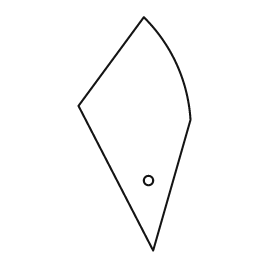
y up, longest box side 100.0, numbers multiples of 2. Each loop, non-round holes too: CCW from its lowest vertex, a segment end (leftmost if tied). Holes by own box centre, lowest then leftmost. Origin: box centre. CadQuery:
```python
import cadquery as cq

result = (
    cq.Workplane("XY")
    .moveTo(8.0, -50.0)
    .lineTo(24.0, 6.0)
    .threePointArc((18.0, 30.0), (4.0, 50.0))
    .lineTo(-24.0, 12.0)
    .close()
    .moveTo(6.0, -20.0)
    .circle(2.0)
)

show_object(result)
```